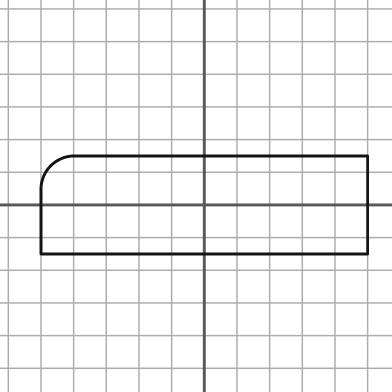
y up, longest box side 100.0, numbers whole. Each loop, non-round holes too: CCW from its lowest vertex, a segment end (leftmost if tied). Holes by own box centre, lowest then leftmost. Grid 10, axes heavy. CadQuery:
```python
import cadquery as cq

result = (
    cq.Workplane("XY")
    .moveTo(-50.0, -15.0)
    .lineTo(50.0, -15.0)
    .lineTo(50.0, 15.0)
    .lineTo(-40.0, 15.0)
    .threePointArc((-47.0, 12.0), (-50.0, 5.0))
    .close()
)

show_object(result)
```